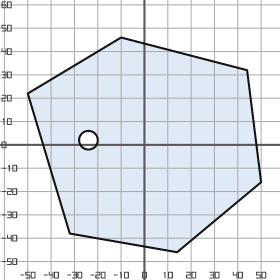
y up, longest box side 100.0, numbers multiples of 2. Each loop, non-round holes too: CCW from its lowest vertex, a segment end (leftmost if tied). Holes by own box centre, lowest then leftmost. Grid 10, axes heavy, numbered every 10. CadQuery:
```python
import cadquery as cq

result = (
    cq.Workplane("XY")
    .moveTo(14.0, -46.0)
    .lineTo(50.0, -16.0)
    .lineTo(44.0, 32.0)
    .lineTo(-10.0, 46.0)
    .lineTo(-50.0, 22.0)
    .lineTo(-32.0, -38.0)
    .close()
    .moveTo(-24.0, 2.0)
    .circle(4.0)
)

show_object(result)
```